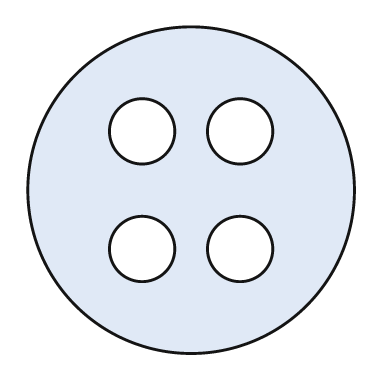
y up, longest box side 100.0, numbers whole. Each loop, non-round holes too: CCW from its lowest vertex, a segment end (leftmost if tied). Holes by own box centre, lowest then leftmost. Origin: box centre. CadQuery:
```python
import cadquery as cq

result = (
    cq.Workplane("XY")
    .moveTo(0.0, 0.0)
    .circle(50.0)
    .moveTo(-15.0, -18.0)
    .circle(10.0)
    .moveTo(15.0, -18.0)
    .circle(10.0)
    .moveTo(-15.0, 18.0)
    .circle(10.0)
    .moveTo(15.0, 18.0)
    .circle(10.0)
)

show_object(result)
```